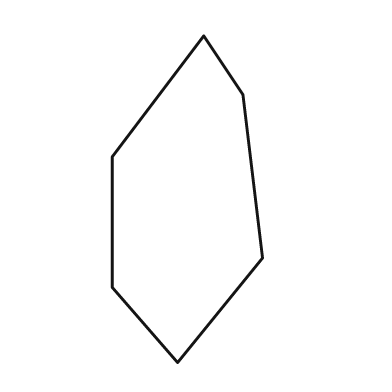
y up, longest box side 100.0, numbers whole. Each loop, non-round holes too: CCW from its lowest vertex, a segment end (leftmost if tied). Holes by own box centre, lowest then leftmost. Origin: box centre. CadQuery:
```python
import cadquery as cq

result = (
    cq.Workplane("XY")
    .moveTo(-3.0, -50.0)
    .lineTo(23.0, -18.0)
    .lineTo(17.0, 32.0)
    .lineTo(5.0, 50.0)
    .lineTo(-23.0, 13.0)
    .lineTo(-23.0, -27.0)
    .close()
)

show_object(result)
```